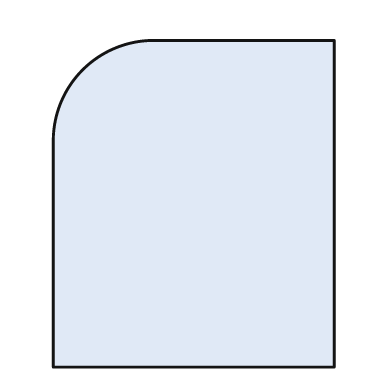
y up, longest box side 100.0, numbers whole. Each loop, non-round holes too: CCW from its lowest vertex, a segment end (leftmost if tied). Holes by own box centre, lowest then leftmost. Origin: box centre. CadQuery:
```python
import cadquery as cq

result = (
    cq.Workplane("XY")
    .moveTo(-43.0, -50.0)
    .lineTo(43.0, -50.0)
    .lineTo(43.0, 50.0)
    .lineTo(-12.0, 50.0)
    .threePointArc((-34.0, 41.0), (-43.0, 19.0))
    .close()
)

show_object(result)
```